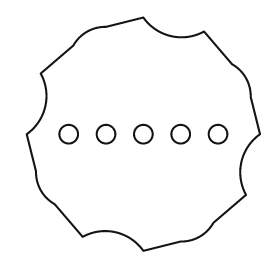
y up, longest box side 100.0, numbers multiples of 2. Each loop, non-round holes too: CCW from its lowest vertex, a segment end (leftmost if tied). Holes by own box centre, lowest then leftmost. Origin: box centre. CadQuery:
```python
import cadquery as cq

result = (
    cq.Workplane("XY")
    .moveTo(0.0, -50.0)
    .lineTo(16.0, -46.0)
    .threePointArc((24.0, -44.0), (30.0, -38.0))
    .lineTo(44.0, -26.0)
    .threePointArc((42.0, -12.0), (50.0, 0.0))
    .lineTo(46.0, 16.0)
    .threePointArc((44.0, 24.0), (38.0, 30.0))
    .lineTo(26.0, 44.0)
    .threePointArc((12.0, 42.0), (0.0, 50.0))
    .lineTo(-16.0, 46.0)
    .threePointArc((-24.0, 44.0), (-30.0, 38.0))
    .lineTo(-44.0, 26.0)
    .threePointArc((-42.0, 12.0), (-50.0, 0.0))
    .lineTo(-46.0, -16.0)
    .threePointArc((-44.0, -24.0), (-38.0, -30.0))
    .lineTo(-26.0, -44.0)
    .threePointArc((-12.0, -42.0), (0.0, -50.0))
    .close()
    .moveTo(-32.0, 0.0)
    .circle(4.0)
    .moveTo(-16.0, 0.0)
    .circle(4.0)
    .moveTo(0.0, 0.0)
    .circle(4.0)
    .moveTo(16.0, 0.0)
    .circle(4.0)
    .moveTo(32.0, 0.0)
    .circle(4.0)
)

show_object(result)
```